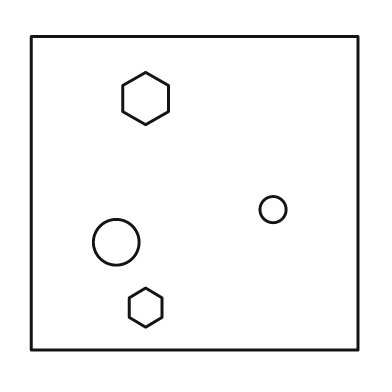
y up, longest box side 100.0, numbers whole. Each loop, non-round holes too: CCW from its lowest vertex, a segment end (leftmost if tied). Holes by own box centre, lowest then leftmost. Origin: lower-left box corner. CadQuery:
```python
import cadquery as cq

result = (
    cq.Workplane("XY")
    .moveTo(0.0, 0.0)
    .lineTo(100.0, 0.0)
    .lineTo(100.0, 96.0)
    .lineTo(0.0, 96.0)
    .close()
    .moveTo(35.0, 7.0)
    .lineTo(40.0, 10.0)
    .lineTo(40.0, 16.0)
    .lineTo(35.0, 19.0)
    .lineTo(30.0, 16.0)
    .lineTo(30.0, 10.0)
    .close()
    .moveTo(26.0, 33.0)
    .circle(7.0)
    .moveTo(74.0, 43.0)
    .circle(4.0)
    .moveTo(35.0, 69.0)
    .lineTo(42.0, 73.0)
    .lineTo(42.0, 81.0)
    .lineTo(35.0, 85.0)
    .lineTo(28.0, 81.0)
    .lineTo(28.0, 73.0)
    .close()
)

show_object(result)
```